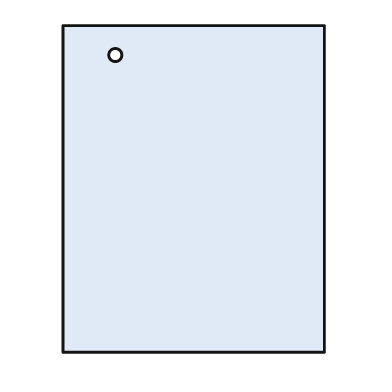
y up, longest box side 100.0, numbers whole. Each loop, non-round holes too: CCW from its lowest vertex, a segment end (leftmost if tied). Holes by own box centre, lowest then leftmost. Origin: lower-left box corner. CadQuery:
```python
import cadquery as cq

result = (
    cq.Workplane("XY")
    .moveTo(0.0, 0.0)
    .lineTo(80.0, 0.0)
    .lineTo(80.0, 100.0)
    .lineTo(0.0, 100.0)
    .close()
    .moveTo(16.0, 91.0)
    .circle(2.0)
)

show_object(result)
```